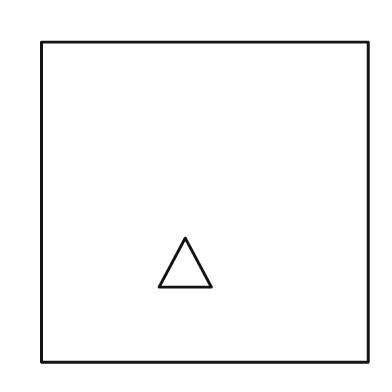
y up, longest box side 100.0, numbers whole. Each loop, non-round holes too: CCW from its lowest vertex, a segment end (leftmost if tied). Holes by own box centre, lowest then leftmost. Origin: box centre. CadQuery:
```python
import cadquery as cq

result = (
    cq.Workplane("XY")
    .moveTo(-50.0, -49.0)
    .lineTo(50.0, -49.0)
    .lineTo(50.0, 49.0)
    .lineTo(-50.0, 49.0)
    .close()
    .moveTo(-14.0, -26.0)
    .lineTo(2.0, -26.0)
    .lineTo(-6.0, -11.0)
    .close()
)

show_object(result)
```